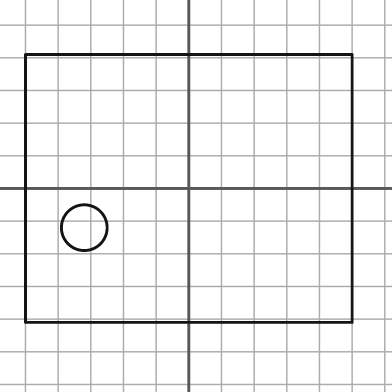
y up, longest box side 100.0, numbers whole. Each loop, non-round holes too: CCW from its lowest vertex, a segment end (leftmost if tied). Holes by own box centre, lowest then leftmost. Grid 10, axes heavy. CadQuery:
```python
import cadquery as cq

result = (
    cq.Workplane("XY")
    .moveTo(-50.0, -41.0)
    .lineTo(50.0, -41.0)
    .lineTo(50.0, 41.0)
    .lineTo(-50.0, 41.0)
    .close()
    .moveTo(-32.0, -12.0)
    .circle(7.0)
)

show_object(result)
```